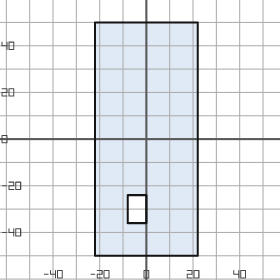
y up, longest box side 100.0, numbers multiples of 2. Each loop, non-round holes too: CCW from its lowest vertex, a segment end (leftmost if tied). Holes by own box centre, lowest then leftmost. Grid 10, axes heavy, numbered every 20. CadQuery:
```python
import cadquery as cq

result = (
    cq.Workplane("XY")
    .moveTo(-22.0, -50.0)
    .lineTo(22.0, -50.0)
    .lineTo(22.0, 50.0)
    .lineTo(-22.0, 50.0)
    .close()
    .moveTo(-8.0, -36.0)
    .lineTo(0.0, -36.0)
    .lineTo(0.0, -24.0)
    .lineTo(-8.0, -24.0)
    .close()
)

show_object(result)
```